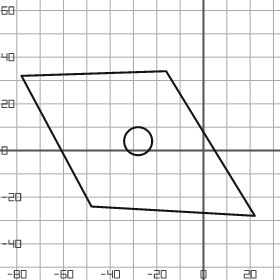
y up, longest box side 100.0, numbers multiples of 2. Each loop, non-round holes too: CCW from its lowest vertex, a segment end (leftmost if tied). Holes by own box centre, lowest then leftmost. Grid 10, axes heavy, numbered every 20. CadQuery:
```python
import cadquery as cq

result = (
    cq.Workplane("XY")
    .moveTo(22.0, -28.0)
    .lineTo(-16.0, 34.0)
    .lineTo(-78.0, 32.0)
    .lineTo(-48.0, -24.0)
    .close()
    .moveTo(-28.0, 4.0)
    .circle(6.0)
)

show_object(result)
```